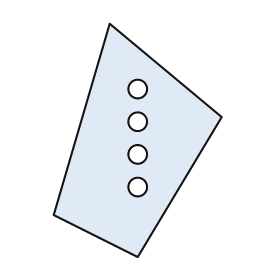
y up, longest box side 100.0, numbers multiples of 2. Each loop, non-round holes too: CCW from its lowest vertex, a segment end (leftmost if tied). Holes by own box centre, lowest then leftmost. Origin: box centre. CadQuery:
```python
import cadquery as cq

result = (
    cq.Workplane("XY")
    .moveTo(0.0, -50.0)
    .lineTo(36.0, 10.0)
    .lineTo(-12.0, 50.0)
    .lineTo(-36.0, -32.0)
    .close()
    .moveTo(0.0, -20.0)
    .circle(4.0)
    .moveTo(0.0, -6.0)
    .circle(4.0)
    .moveTo(0.0, 8.0)
    .circle(4.0)
    .moveTo(0.0, 22.0)
    .circle(4.0)
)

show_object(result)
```